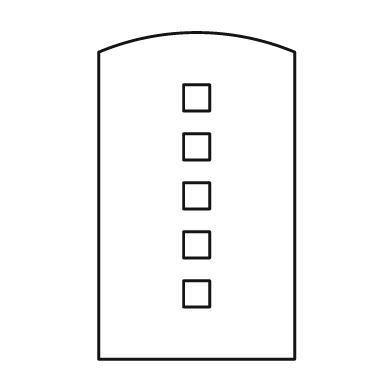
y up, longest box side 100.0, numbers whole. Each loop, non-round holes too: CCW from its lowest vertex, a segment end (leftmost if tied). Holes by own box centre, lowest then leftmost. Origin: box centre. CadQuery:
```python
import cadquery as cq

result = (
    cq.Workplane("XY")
    .moveTo(-30.0, -50.0)
    .lineTo(30.0, -50.0)
    .lineTo(30.0, 44.0)
    .threePointArc((0.0, 50.0), (-30.0, 44.0))
    .close()
    .moveTo(-4.0, -34.0)
    .lineTo(4.0, -34.0)
    .lineTo(4.0, -26.0)
    .lineTo(-4.0, -26.0)
    .close()
    .moveTo(-4.0, -19.0)
    .lineTo(4.0, -19.0)
    .lineTo(4.0, -11.0)
    .lineTo(-4.0, -11.0)
    .close()
    .moveTo(-4.0, -4.0)
    .lineTo(4.0, -4.0)
    .lineTo(4.0, 4.0)
    .lineTo(-4.0, 4.0)
    .close()
    .moveTo(-4.0, 11.0)
    .lineTo(4.0, 11.0)
    .lineTo(4.0, 19.0)
    .lineTo(-4.0, 19.0)
    .close()
    .moveTo(-4.0, 26.0)
    .lineTo(4.0, 26.0)
    .lineTo(4.0, 34.0)
    .lineTo(-4.0, 34.0)
    .close()
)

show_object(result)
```